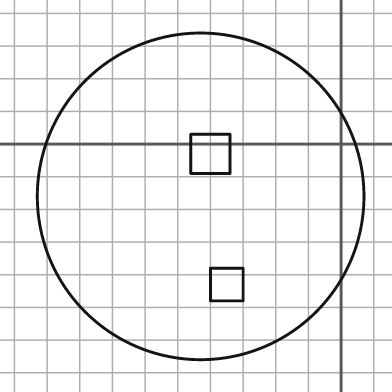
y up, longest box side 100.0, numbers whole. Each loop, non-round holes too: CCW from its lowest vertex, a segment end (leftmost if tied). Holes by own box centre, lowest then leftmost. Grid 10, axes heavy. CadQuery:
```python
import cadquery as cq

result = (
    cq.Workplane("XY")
    .moveTo(-43.0, -16.0)
    .circle(50.0)
    .moveTo(-40.0, -48.0)
    .lineTo(-30.0, -48.0)
    .lineTo(-30.0, -38.0)
    .lineTo(-40.0, -38.0)
    .close()
    .moveTo(-46.0, -9.0)
    .lineTo(-34.0, -9.0)
    .lineTo(-34.0, 3.0)
    .lineTo(-46.0, 3.0)
    .close()
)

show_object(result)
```